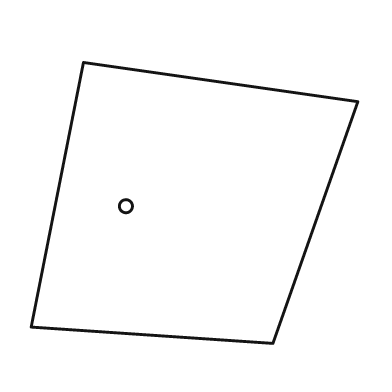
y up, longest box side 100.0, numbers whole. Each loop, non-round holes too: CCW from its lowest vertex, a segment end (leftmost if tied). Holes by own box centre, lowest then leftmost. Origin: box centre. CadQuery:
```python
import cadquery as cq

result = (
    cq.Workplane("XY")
    .moveTo(24.0, -43.0)
    .lineTo(50.0, 31.0)
    .lineTo(-34.0, 43.0)
    .lineTo(-50.0, -38.0)
    .close()
    .moveTo(-21.0, -1.0)
    .circle(2.0)
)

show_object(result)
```